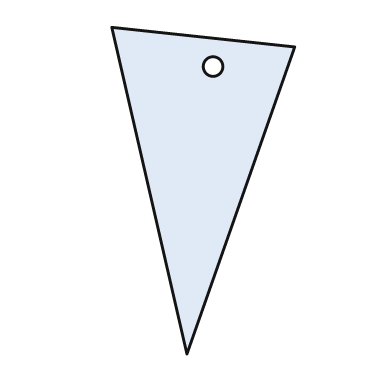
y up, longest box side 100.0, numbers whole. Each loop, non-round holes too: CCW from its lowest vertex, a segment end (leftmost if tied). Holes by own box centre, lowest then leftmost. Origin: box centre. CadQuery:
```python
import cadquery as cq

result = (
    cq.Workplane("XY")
    .moveTo(-5.0, -50.0)
    .lineTo(28.0, 44.0)
    .lineTo(-28.0, 50.0)
    .close()
    .moveTo(3.0, 38.0)
    .circle(3.0)
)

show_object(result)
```